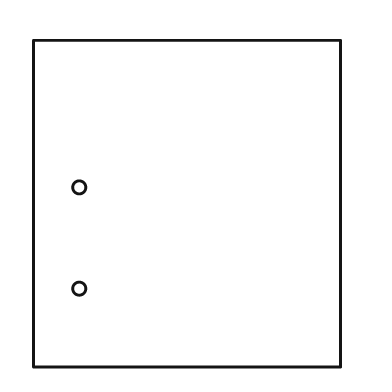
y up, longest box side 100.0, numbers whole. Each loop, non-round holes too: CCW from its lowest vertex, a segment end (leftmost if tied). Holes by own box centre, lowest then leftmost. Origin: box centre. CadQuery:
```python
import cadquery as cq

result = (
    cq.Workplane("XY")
    .moveTo(-47.0, -50.0)
    .lineTo(47.0, -50.0)
    .lineTo(47.0, 50.0)
    .lineTo(-47.0, 50.0)
    .close()
    .moveTo(-33.0, -26.0)
    .circle(2.0)
    .moveTo(-33.0, 5.0)
    .circle(2.0)
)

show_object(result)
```